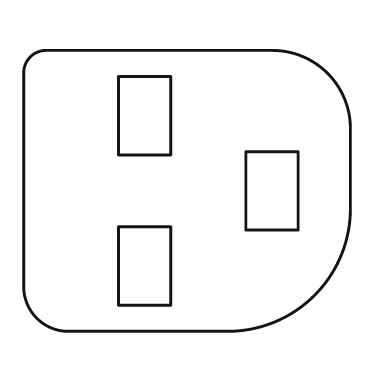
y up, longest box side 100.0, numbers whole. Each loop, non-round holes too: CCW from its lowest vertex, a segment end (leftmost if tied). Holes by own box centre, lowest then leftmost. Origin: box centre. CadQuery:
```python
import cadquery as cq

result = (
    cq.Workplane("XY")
    .moveTo(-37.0, -43.0)
    .lineTo(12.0, -43.0)
    .threePointArc((39.0, -32.0), (50.0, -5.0))
    .lineTo(50.0, 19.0)
    .threePointArc((43.0, 36.0), (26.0, 43.0))
    .lineTo(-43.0, 43.0)
    .threePointArc((-48.0, 41.0), (-50.0, 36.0))
    .lineTo(-50.0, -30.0)
    .threePointArc((-46.0, -39.0), (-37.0, -43.0))
    .close()
    .moveTo(-21.0, -35.0)
    .lineTo(-5.0, -35.0)
    .lineTo(-5.0, -11.0)
    .lineTo(-21.0, -11.0)
    .close()
    .moveTo(18.0, -12.0)
    .lineTo(34.0, -12.0)
    .lineTo(34.0, 12.0)
    .lineTo(18.0, 12.0)
    .close()
    .moveTo(-21.0, 11.0)
    .lineTo(-5.0, 11.0)
    .lineTo(-5.0, 35.0)
    .lineTo(-21.0, 35.0)
    .close()
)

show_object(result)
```